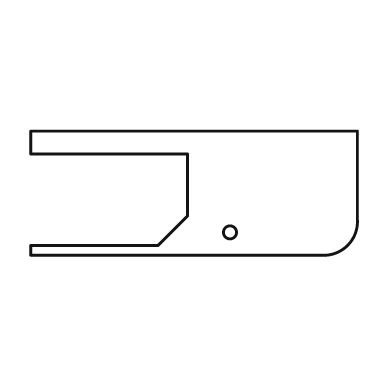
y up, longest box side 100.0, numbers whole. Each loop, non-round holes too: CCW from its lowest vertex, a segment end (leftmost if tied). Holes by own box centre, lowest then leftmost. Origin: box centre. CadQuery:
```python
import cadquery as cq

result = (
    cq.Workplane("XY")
    .moveTo(-50.0, -19.0)
    .lineTo(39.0, -19.0)
    .threePointArc((47.0, -16.0), (50.0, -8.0))
    .lineTo(50.0, 19.0)
    .lineTo(-50.0, 19.0)
    .lineTo(-50.0, 12.0)
    .lineTo(-2.0, 12.0)
    .lineTo(-2.0, -7.0)
    .lineTo(-11.0, -16.0)
    .lineTo(-50.0, -16.0)
    .close()
    .moveTo(11.0, -12.0)
    .circle(2.0)
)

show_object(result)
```